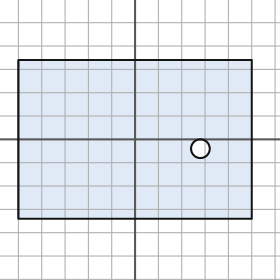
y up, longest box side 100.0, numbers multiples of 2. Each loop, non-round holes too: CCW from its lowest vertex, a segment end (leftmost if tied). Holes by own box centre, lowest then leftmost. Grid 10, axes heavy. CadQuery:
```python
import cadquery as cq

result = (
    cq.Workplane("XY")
    .moveTo(-50.0, -34.0)
    .lineTo(50.0, -34.0)
    .lineTo(50.0, 34.0)
    .lineTo(-50.0, 34.0)
    .close()
    .moveTo(28.0, -4.0)
    .circle(4.0)
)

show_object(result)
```